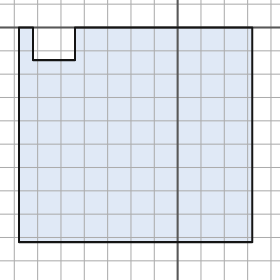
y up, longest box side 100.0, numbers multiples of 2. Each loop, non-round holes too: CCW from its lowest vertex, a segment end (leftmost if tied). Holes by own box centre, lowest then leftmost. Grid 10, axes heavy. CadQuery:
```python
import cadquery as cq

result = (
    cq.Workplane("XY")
    .moveTo(-68.0, -92.0)
    .lineTo(32.0, -92.0)
    .lineTo(32.0, 0.0)
    .lineTo(-44.0, 0.0)
    .lineTo(-44.0, -14.0)
    .lineTo(-62.0, -14.0)
    .lineTo(-62.0, 0.0)
    .lineTo(-68.0, 0.0)
    .close()
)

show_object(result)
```